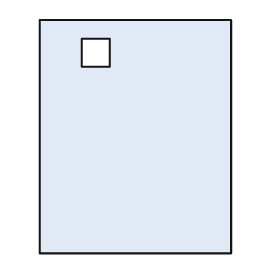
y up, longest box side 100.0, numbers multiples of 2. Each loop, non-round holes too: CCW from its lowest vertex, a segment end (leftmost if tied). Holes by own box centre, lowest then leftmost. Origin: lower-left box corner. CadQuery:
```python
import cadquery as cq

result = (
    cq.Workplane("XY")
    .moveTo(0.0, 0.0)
    .lineTo(82.0, 0.0)
    .lineTo(82.0, 100.0)
    .lineTo(0.0, 100.0)
    .close()
    .moveTo(18.0, 80.0)
    .lineTo(30.0, 80.0)
    .lineTo(30.0, 92.0)
    .lineTo(18.0, 92.0)
    .close()
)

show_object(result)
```